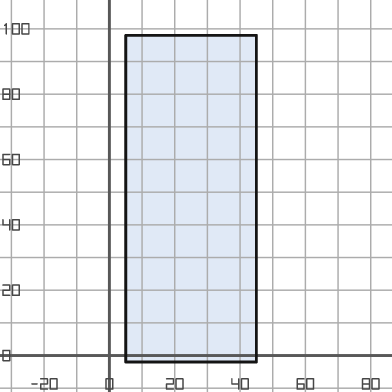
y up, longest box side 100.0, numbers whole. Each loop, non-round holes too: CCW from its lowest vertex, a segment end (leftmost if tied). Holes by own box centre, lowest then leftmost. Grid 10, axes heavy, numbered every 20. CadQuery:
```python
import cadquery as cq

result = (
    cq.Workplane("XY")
    .moveTo(5.0, -2.0)
    .lineTo(45.0, -2.0)
    .lineTo(45.0, 98.0)
    .lineTo(5.0, 98.0)
    .close()
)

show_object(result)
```